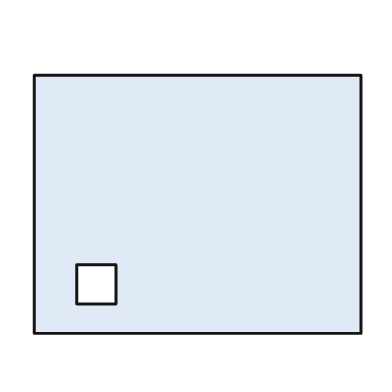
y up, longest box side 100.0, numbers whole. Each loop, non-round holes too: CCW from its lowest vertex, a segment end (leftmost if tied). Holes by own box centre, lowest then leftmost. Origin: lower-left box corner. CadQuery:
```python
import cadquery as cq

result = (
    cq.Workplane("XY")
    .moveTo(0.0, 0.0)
    .lineTo(100.0, 0.0)
    .lineTo(100.0, 79.0)
    .lineTo(0.0, 79.0)
    .close()
    .moveTo(13.0, 9.0)
    .lineTo(25.0, 9.0)
    .lineTo(25.0, 21.0)
    .lineTo(13.0, 21.0)
    .close()
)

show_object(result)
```